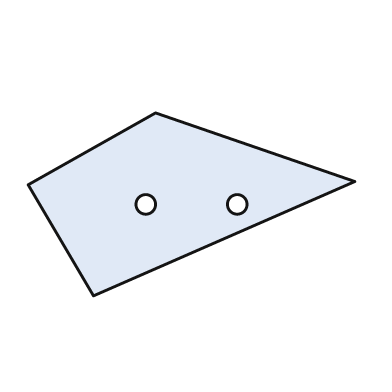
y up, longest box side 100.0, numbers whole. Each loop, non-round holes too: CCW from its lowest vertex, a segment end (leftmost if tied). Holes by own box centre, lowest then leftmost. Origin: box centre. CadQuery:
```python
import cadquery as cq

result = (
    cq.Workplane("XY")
    .moveTo(-30.0, -28.0)
    .lineTo(50.0, 7.0)
    .lineTo(-11.0, 28.0)
    .lineTo(-50.0, 6.0)
    .close()
    .moveTo(-14.0, 0.0)
    .circle(3.0)
    .moveTo(14.0, 0.0)
    .circle(3.0)
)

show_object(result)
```